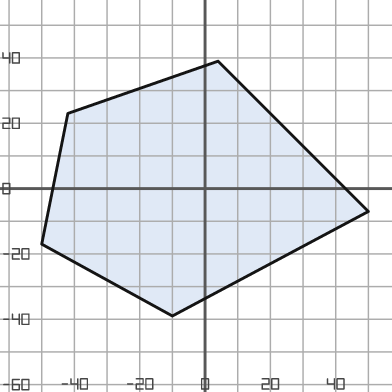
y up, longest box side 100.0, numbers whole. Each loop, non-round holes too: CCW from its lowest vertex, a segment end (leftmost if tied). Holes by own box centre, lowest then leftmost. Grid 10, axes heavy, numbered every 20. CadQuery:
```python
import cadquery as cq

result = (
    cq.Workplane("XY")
    .moveTo(-10.0, -39.0)
    .lineTo(50.0, -7.0)
    .lineTo(4.0, 39.0)
    .lineTo(-42.0, 23.0)
    .lineTo(-50.0, -17.0)
    .close()
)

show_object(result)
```